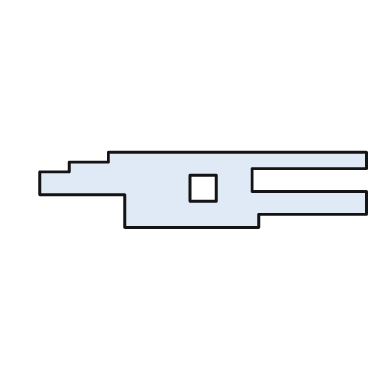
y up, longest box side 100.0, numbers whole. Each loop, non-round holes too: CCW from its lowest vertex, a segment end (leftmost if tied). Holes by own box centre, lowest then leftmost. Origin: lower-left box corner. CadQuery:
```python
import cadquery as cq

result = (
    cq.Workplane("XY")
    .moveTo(26.0, 0.0)
    .lineTo(67.0, 0.0)
    .lineTo(67.0, 4.0)
    .lineTo(100.0, 4.0)
    .lineTo(100.0, 11.0)
    .lineTo(65.0, 11.0)
    .lineTo(65.0, 18.0)
    .lineTo(100.0, 18.0)
    .lineTo(100.0, 23.0)
    .lineTo(21.0, 23.0)
    .lineTo(21.0, 20.0)
    .lineTo(9.0, 20.0)
    .lineTo(9.0, 17.0)
    .lineTo(0.0, 17.0)
    .lineTo(0.0, 10.0)
    .lineTo(26.0, 10.0)
    .close()
    .moveTo(46.0, 8.0)
    .lineTo(54.0, 8.0)
    .lineTo(54.0, 16.0)
    .lineTo(46.0, 16.0)
    .close()
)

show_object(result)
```